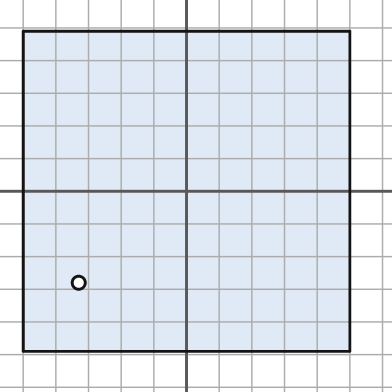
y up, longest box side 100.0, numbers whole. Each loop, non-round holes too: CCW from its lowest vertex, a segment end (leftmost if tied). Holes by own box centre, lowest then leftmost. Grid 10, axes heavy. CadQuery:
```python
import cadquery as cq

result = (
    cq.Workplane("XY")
    .moveTo(-50.0, -49.0)
    .lineTo(50.0, -49.0)
    .lineTo(50.0, 49.0)
    .lineTo(-50.0, 49.0)
    .close()
    .moveTo(-33.0, -28.0)
    .circle(2.0)
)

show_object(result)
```